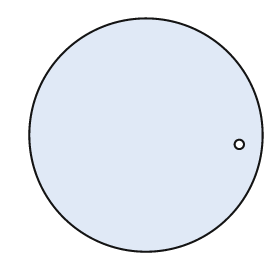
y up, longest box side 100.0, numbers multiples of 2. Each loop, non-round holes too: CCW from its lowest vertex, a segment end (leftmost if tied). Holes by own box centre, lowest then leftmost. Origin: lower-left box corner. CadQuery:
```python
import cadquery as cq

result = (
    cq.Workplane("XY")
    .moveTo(50.0, 50.0)
    .circle(50.0)
    .moveTo(90.0, 46.0)
    .circle(2.0)
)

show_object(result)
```